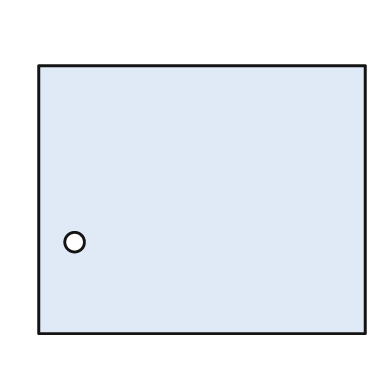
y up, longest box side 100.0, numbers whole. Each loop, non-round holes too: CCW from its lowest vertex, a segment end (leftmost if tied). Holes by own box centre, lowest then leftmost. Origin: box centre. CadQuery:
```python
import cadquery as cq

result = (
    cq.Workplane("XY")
    .moveTo(-50.0, -41.0)
    .lineTo(50.0, -41.0)
    .lineTo(50.0, 41.0)
    .lineTo(-50.0, 41.0)
    .close()
    .moveTo(-39.0, -13.0)
    .circle(3.0)
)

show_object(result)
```